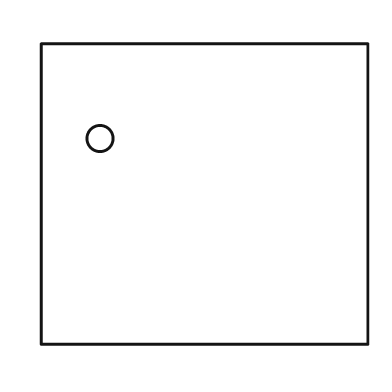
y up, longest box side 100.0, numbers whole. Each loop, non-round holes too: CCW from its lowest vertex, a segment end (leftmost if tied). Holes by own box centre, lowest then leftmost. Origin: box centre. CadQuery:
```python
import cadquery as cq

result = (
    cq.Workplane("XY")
    .moveTo(-50.0, -46.0)
    .lineTo(50.0, -46.0)
    .lineTo(50.0, 46.0)
    .lineTo(-50.0, 46.0)
    .close()
    .moveTo(-32.0, 17.0)
    .circle(4.0)
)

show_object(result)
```